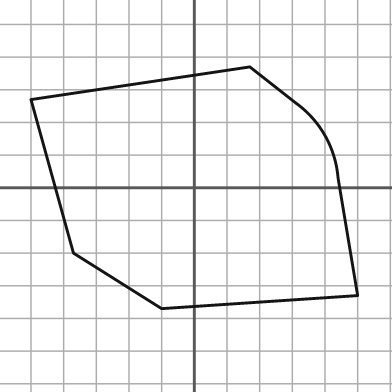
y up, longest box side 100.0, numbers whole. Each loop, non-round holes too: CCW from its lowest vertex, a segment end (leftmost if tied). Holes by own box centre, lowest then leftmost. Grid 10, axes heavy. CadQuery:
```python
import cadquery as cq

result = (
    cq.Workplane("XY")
    .moveTo(-10.0, -37.0)
    .lineTo(50.0, -33.0)
    .lineTo(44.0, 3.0)
    .threePointArc((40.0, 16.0), (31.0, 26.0))
    .lineTo(17.0, 37.0)
    .lineTo(-50.0, 27.0)
    .lineTo(-37.0, -20.0)
    .close()
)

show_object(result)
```